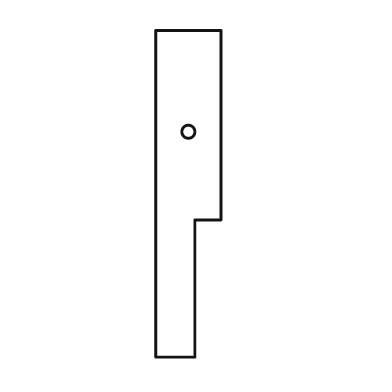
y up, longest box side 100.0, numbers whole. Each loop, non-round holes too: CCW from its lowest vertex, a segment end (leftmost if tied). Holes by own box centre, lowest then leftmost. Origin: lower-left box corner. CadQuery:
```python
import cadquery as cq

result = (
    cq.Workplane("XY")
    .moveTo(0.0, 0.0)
    .lineTo(12.0, 0.0)
    .lineTo(12.0, 42.0)
    .lineTo(20.0, 42.0)
    .lineTo(20.0, 100.0)
    .lineTo(0.0, 100.0)
    .close()
    .moveTo(10.0, 69.0)
    .circle(2.0)
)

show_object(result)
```